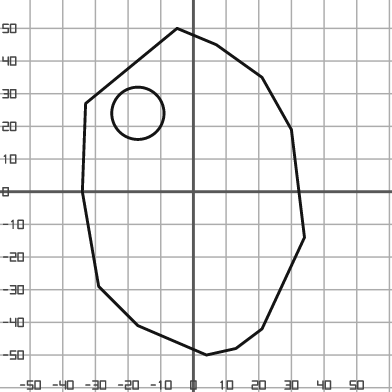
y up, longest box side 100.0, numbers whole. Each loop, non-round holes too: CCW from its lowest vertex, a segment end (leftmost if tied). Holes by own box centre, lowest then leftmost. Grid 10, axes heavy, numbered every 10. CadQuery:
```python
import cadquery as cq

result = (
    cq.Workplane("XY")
    .moveTo(4.0, -50.0)
    .lineTo(13.0, -48.0)
    .lineTo(21.0, -42.0)
    .lineTo(34.0, -14.0)
    .lineTo(30.0, 19.0)
    .lineTo(21.0, 35.0)
    .lineTo(7.0, 45.0)
    .lineTo(-5.0, 50.0)
    .lineTo(-33.0, 27.0)
    .lineTo(-34.0, 0.0)
    .lineTo(-29.0, -29.0)
    .lineTo(-17.0, -41.0)
    .close()
    .moveTo(-17.0, 24.0)
    .circle(8.0)
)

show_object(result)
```